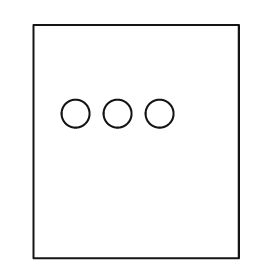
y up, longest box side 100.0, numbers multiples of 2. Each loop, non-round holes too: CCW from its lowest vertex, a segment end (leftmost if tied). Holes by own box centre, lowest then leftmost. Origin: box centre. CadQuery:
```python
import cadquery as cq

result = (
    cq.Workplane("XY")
    .moveTo(-44.0, -50.0)
    .lineTo(44.0, -50.0)
    .lineTo(44.0, 50.0)
    .lineTo(-44.0, 50.0)
    .close()
    .moveTo(-26.0, 12.0)
    .circle(6.0)
    .moveTo(-8.0, 12.0)
    .circle(6.0)
    .moveTo(10.0, 12.0)
    .circle(6.0)
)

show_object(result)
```